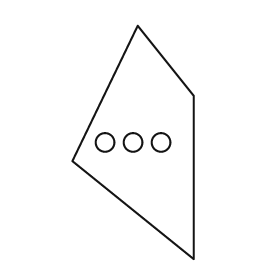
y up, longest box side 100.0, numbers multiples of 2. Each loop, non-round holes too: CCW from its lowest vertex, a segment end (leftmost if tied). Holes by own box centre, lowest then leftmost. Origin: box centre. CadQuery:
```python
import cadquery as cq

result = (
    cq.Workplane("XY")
    .moveTo(26.0, -50.0)
    .lineTo(26.0, 20.0)
    .lineTo(2.0, 50.0)
    .lineTo(-26.0, -8.0)
    .close()
    .moveTo(-12.0, 0.0)
    .circle(4.0)
    .moveTo(0.0, 0.0)
    .circle(4.0)
    .moveTo(12.0, 0.0)
    .circle(4.0)
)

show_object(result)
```